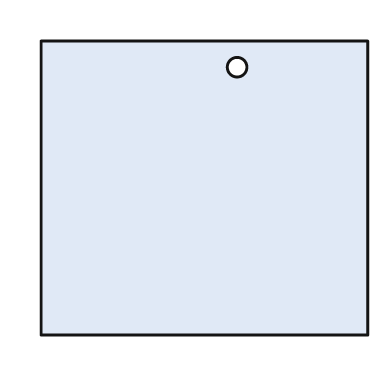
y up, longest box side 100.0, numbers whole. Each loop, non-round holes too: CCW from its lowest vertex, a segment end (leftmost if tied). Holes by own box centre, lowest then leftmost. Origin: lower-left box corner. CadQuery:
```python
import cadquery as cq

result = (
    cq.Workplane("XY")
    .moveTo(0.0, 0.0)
    .lineTo(100.0, 0.0)
    .lineTo(100.0, 90.0)
    .lineTo(0.0, 90.0)
    .close()
    .moveTo(60.0, 82.0)
    .circle(3.0)
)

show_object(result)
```